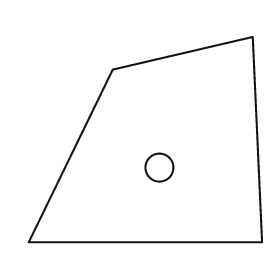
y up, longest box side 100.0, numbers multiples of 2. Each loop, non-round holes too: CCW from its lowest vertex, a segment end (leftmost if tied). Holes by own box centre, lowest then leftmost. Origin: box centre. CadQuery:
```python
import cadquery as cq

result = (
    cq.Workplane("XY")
    .moveTo(-50.0, -44.0)
    .lineTo(50.0, -44.0)
    .lineTo(46.0, 44.0)
    .lineTo(-14.0, 30.0)
    .close()
    .moveTo(6.0, -12.0)
    .circle(6.0)
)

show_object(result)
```